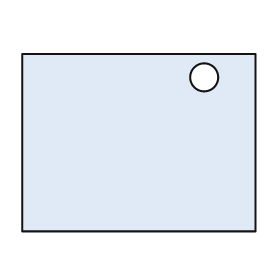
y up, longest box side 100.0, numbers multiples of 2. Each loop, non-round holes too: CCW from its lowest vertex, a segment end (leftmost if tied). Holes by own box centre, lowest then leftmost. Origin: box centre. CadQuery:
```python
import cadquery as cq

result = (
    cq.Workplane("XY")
    .moveTo(-50.0, -38.0)
    .lineTo(50.0, -38.0)
    .lineTo(50.0, 38.0)
    .lineTo(-50.0, 38.0)
    .close()
    .moveTo(28.0, 28.0)
    .circle(6.0)
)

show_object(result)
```